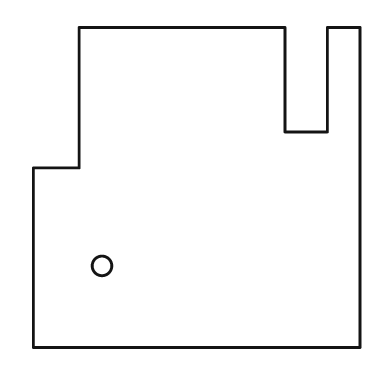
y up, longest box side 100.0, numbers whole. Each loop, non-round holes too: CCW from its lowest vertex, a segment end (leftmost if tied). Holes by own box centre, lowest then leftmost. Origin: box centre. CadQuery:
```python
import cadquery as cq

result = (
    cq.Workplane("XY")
    .moveTo(-50.0, -49.0)
    .lineTo(50.0, -49.0)
    .lineTo(50.0, 49.0)
    .lineTo(40.0, 49.0)
    .lineTo(40.0, 17.0)
    .lineTo(27.0, 17.0)
    .lineTo(27.0, 49.0)
    .lineTo(-36.0, 49.0)
    .lineTo(-36.0, 6.0)
    .lineTo(-50.0, 6.0)
    .close()
    .moveTo(-29.0, -24.0)
    .circle(3.0)
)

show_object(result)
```